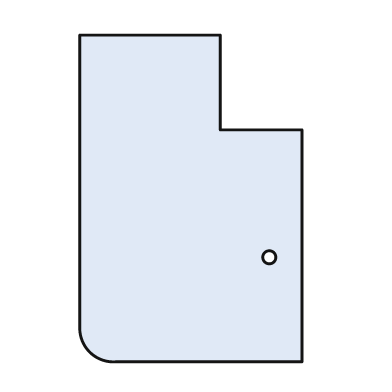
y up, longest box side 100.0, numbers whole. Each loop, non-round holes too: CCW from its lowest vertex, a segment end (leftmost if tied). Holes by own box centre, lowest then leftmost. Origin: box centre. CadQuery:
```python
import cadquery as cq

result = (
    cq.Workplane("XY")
    .moveTo(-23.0, -50.0)
    .lineTo(34.0, -50.0)
    .lineTo(34.0, 21.0)
    .lineTo(9.0, 21.0)
    .lineTo(9.0, 50.0)
    .lineTo(-34.0, 50.0)
    .lineTo(-34.0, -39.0)
    .threePointArc((-31.0, -47.0), (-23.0, -50.0))
    .close()
    .moveTo(24.0, -18.0)
    .circle(2.0)
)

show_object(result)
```